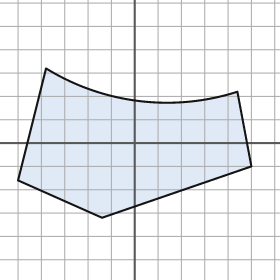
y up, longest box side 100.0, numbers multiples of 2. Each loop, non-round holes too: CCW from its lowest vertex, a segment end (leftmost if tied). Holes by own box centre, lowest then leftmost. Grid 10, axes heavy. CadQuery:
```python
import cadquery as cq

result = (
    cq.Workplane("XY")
    .moveTo(-14.0, -32.0)
    .lineTo(50.0, -10.0)
    .lineTo(44.0, 22.0)
    .threePointArc((2.0, 18.0), (-38.0, 32.0))
    .lineTo(-50.0, -16.0)
    .close()
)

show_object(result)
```